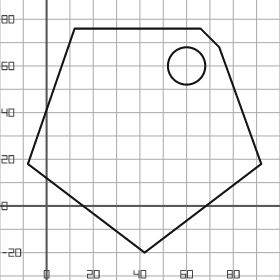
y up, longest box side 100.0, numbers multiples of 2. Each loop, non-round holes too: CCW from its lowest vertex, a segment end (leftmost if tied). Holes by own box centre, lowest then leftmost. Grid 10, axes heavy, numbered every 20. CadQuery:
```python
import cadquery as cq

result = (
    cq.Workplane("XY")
    .moveTo(42.0, -20.0)
    .lineTo(92.0, 18.0)
    .lineTo(74.0, 68.0)
    .lineTo(66.0, 76.0)
    .lineTo(12.0, 76.0)
    .lineTo(-8.0, 18.0)
    .close()
    .moveTo(60.0, 60.0)
    .circle(8.0)
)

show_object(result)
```